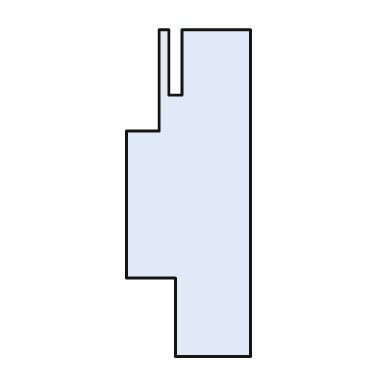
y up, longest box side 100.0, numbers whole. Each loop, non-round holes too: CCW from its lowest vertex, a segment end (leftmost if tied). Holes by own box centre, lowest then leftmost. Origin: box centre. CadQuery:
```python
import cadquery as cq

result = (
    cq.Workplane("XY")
    .moveTo(-4.0, -50.0)
    .lineTo(19.0, -50.0)
    .lineTo(19.0, 50.0)
    .lineTo(-2.0, 50.0)
    .lineTo(-2.0, 30.0)
    .lineTo(-6.0, 30.0)
    .lineTo(-6.0, 50.0)
    .lineTo(-9.0, 50.0)
    .lineTo(-9.0, 19.0)
    .lineTo(-19.0, 19.0)
    .lineTo(-19.0, -26.0)
    .lineTo(-4.0, -26.0)
    .close()
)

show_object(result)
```